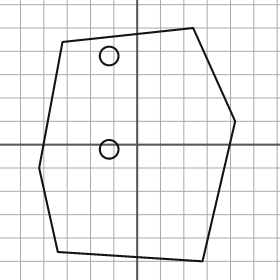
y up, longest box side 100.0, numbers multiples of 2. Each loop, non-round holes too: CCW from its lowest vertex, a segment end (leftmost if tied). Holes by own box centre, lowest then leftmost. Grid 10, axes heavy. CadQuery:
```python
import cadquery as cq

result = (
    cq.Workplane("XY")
    .moveTo(28.0, -50.0)
    .lineTo(42.0, 10.0)
    .lineTo(24.0, 50.0)
    .lineTo(-32.0, 44.0)
    .lineTo(-42.0, -10.0)
    .lineTo(-34.0, -46.0)
    .close()
    .moveTo(-12.0, -2.0)
    .circle(4.0)
    .moveTo(-12.0, 38.0)
    .circle(4.0)
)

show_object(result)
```